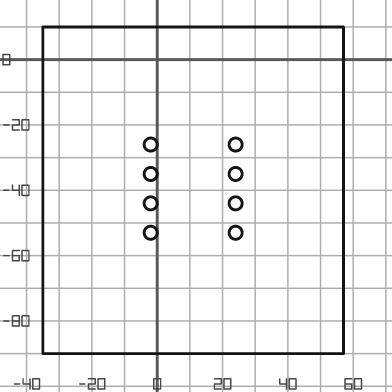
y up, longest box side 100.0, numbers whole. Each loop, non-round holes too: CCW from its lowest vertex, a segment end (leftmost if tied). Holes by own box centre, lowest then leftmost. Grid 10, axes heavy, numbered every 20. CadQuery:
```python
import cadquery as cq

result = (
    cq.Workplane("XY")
    .moveTo(-35.0, -90.0)
    .lineTo(57.0, -90.0)
    .lineTo(57.0, 10.0)
    .lineTo(-35.0, 10.0)
    .close()
    .moveTo(-2.0, -53.0)
    .circle(2.0)
    .moveTo(24.0, -53.0)
    .circle(2.0)
    .moveTo(-2.0, -44.0)
    .circle(2.0)
    .moveTo(24.0, -44.0)
    .circle(2.0)
    .moveTo(-2.0, -35.0)
    .circle(2.0)
    .moveTo(24.0, -35.0)
    .circle(2.0)
    .moveTo(-2.0, -26.0)
    .circle(2.0)
    .moveTo(24.0, -26.0)
    .circle(2.0)
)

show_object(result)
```